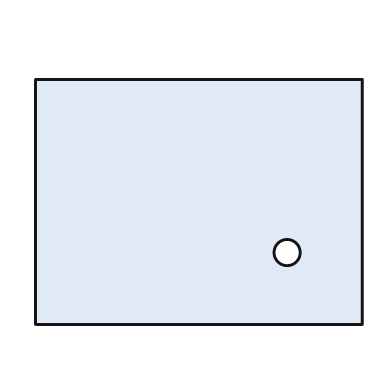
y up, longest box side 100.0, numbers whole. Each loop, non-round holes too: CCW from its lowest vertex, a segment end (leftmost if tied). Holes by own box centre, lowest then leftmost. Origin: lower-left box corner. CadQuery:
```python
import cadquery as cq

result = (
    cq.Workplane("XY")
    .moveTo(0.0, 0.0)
    .lineTo(100.0, 0.0)
    .lineTo(100.0, 75.0)
    .lineTo(0.0, 75.0)
    .close()
    .moveTo(77.0, 22.0)
    .circle(4.0)
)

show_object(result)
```